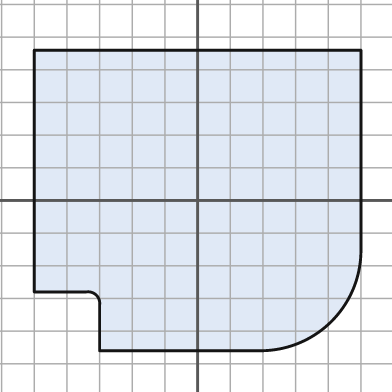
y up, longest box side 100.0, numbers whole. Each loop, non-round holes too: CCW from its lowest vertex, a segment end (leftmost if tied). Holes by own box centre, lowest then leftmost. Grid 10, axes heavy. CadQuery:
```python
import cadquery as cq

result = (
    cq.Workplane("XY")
    .moveTo(-30.0, -46.0)
    .lineTo(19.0, -46.0)
    .threePointArc((41.0, -37.0), (50.0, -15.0))
    .lineTo(50.0, 46.0)
    .lineTo(-50.0, 46.0)
    .lineTo(-50.0, -28.0)
    .lineTo(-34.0, -28.0)
    .threePointArc((-31.0, -29.0), (-30.0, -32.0))
    .close()
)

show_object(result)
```